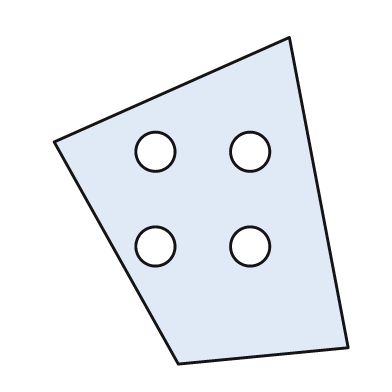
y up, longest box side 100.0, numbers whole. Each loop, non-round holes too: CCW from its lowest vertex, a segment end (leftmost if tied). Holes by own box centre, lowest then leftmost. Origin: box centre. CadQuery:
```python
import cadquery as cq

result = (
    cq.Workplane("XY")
    .moveTo(-7.0, -50.0)
    .lineTo(45.0, -45.0)
    .lineTo(27.0, 50.0)
    .lineTo(-45.0, 18.0)
    .close()
    .moveTo(-14.0, -14.0)
    .circle(6.0)
    .moveTo(15.0, -14.0)
    .circle(6.0)
    .moveTo(-14.0, 15.0)
    .circle(6.0)
    .moveTo(15.0, 15.0)
    .circle(6.0)
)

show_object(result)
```